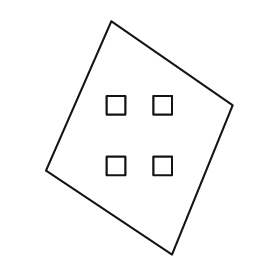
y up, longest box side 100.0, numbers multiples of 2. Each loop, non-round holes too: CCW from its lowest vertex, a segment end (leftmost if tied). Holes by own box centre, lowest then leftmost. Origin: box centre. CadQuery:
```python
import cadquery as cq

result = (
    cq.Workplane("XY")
    .moveTo(14.0, -50.0)
    .lineTo(40.0, 14.0)
    .lineTo(-12.0, 50.0)
    .lineTo(-40.0, -14.0)
    .close()
    .moveTo(-14.0, -16.0)
    .lineTo(-6.0, -16.0)
    .lineTo(-6.0, -8.0)
    .lineTo(-14.0, -8.0)
    .close()
    .moveTo(6.0, -16.0)
    .lineTo(14.0, -16.0)
    .lineTo(14.0, -8.0)
    .lineTo(6.0, -8.0)
    .close()
    .moveTo(-14.0, 10.0)
    .lineTo(-6.0, 10.0)
    .lineTo(-6.0, 18.0)
    .lineTo(-14.0, 18.0)
    .close()
    .moveTo(6.0, 10.0)
    .lineTo(14.0, 10.0)
    .lineTo(14.0, 18.0)
    .lineTo(6.0, 18.0)
    .close()
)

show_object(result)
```